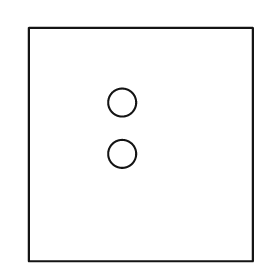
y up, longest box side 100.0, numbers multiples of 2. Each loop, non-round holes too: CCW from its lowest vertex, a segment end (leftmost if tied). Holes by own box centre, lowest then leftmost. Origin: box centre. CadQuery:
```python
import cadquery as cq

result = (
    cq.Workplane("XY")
    .moveTo(-48.0, -50.0)
    .lineTo(48.0, -50.0)
    .lineTo(48.0, 50.0)
    .lineTo(-48.0, 50.0)
    .close()
    .moveTo(-8.0, -4.0)
    .circle(6.0)
    .moveTo(-8.0, 18.0)
    .circle(6.0)
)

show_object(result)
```